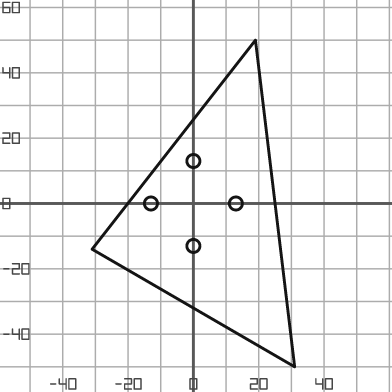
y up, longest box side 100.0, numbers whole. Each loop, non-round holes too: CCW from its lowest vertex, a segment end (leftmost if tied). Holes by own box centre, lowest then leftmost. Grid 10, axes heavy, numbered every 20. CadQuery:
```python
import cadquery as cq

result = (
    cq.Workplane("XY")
    .moveTo(31.0, -50.0)
    .lineTo(19.0, 50.0)
    .lineTo(-31.0, -14.0)
    .close()
    .moveTo(0.0, -13.0)
    .circle(2.0)
    .moveTo(-13.0, 0.0)
    .circle(2.0)
    .moveTo(13.0, 0.0)
    .circle(2.0)
    .moveTo(0.0, 13.0)
    .circle(2.0)
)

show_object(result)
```